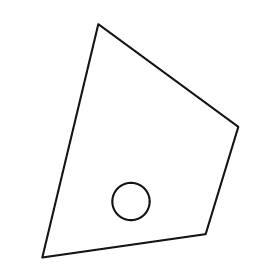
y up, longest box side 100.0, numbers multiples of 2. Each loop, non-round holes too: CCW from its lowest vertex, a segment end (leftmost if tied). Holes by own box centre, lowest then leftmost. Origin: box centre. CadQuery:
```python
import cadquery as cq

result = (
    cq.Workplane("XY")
    .moveTo(-42.0, -50.0)
    .lineTo(28.0, -40.0)
    .lineTo(42.0, 6.0)
    .lineTo(-18.0, 50.0)
    .close()
    .moveTo(-4.0, -26.0)
    .circle(8.0)
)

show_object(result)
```